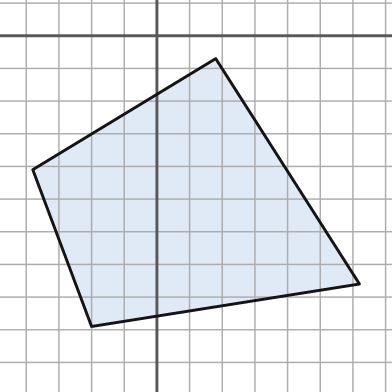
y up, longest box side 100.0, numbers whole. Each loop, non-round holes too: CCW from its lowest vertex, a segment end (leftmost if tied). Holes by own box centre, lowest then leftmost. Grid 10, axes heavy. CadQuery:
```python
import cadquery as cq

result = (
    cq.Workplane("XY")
    .moveTo(-20.0, -89.0)
    .lineTo(62.0, -76.0)
    .lineTo(18.0, -7.0)
    .lineTo(-38.0, -41.0)
    .close()
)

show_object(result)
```